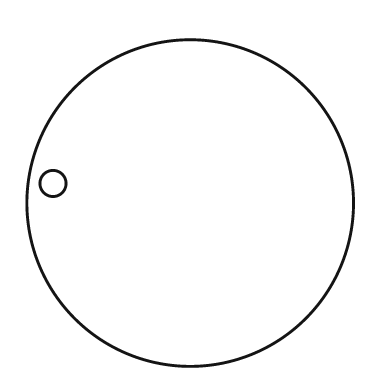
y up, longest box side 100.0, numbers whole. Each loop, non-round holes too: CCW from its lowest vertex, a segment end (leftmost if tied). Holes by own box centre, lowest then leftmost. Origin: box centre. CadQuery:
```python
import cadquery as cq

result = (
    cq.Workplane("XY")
    .moveTo(0.0, 0.0)
    .circle(50.0)
    .moveTo(-42.0, 6.0)
    .circle(4.0)
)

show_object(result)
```